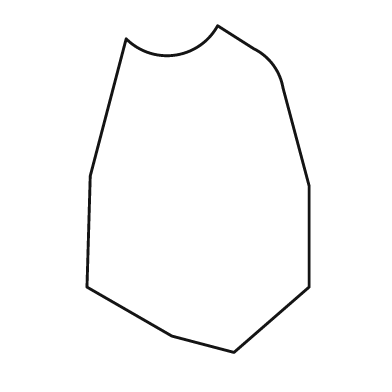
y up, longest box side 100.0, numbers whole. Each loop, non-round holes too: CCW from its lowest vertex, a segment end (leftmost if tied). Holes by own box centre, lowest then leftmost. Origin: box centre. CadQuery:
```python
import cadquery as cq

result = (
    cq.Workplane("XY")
    .moveTo(11.0, -50.0)
    .lineTo(34.0, -30.0)
    .lineTo(34.0, 1.0)
    .lineTo(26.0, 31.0)
    .threePointArc((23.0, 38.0), (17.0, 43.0))
    .lineTo(6.0, 50.0)
    .threePointArc((-7.0, 41.0), (-22.0, 46.0))
    .lineTo(-33.0, 4.0)
    .lineTo(-34.0, -30.0)
    .lineTo(-8.0, -45.0)
    .close()
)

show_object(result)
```